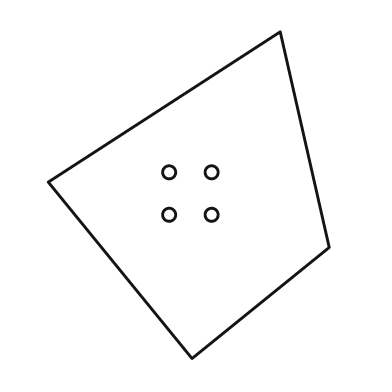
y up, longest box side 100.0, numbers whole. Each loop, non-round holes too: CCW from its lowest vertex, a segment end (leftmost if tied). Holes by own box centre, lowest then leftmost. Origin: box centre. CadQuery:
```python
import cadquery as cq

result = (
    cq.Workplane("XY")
    .moveTo(1.0, -50.0)
    .lineTo(43.0, -16.0)
    .lineTo(28.0, 50.0)
    .lineTo(-43.0, 4.0)
    .close()
    .moveTo(-6.0, -6.0)
    .circle(2.0)
    .moveTo(7.0, -6.0)
    .circle(2.0)
    .moveTo(-6.0, 7.0)
    .circle(2.0)
    .moveTo(7.0, 7.0)
    .circle(2.0)
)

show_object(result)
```